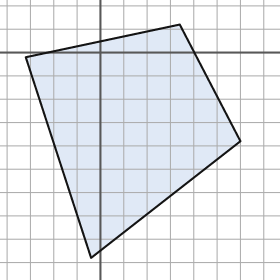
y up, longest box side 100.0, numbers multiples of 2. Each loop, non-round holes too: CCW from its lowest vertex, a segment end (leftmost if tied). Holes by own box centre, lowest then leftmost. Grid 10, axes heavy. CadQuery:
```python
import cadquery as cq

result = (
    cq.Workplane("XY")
    .moveTo(-4.0, -88.0)
    .lineTo(60.0, -38.0)
    .lineTo(34.0, 12.0)
    .lineTo(-32.0, -2.0)
    .close()
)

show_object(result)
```